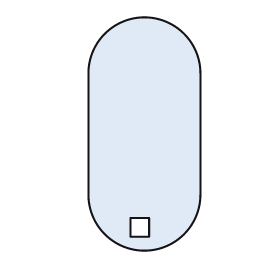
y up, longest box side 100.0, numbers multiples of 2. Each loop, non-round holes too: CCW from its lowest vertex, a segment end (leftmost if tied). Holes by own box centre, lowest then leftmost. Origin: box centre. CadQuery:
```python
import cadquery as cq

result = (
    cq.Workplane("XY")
    .moveTo(-24.0, -26.0)
    .threePointArc((0.0, -50.0), (24.0, -26.0))
    .lineTo(24.0, 26.0)
    .threePointArc((0.0, 50.0), (-24.0, 26.0))
    .close()
    .moveTo(-6.0, -44.0)
    .lineTo(2.0, -44.0)
    .lineTo(2.0, -36.0)
    .lineTo(-6.0, -36.0)
    .close()
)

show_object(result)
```